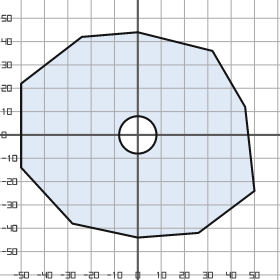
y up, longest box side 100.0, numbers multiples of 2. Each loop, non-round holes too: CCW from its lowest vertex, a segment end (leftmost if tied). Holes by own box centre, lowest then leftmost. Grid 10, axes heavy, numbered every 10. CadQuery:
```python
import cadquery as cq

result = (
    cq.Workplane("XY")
    .moveTo(0.0, -44.0)
    .lineTo(26.0, -42.0)
    .lineTo(50.0, -24.0)
    .lineTo(46.0, 12.0)
    .lineTo(32.0, 36.0)
    .lineTo(0.0, 44.0)
    .lineTo(-24.0, 42.0)
    .lineTo(-50.0, 22.0)
    .lineTo(-50.0, -14.0)
    .lineTo(-28.0, -38.0)
    .close()
    .moveTo(0.0, 0.0)
    .circle(8.0)
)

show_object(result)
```